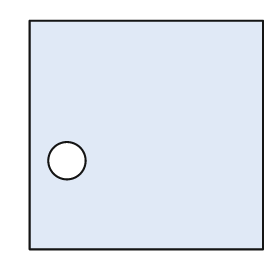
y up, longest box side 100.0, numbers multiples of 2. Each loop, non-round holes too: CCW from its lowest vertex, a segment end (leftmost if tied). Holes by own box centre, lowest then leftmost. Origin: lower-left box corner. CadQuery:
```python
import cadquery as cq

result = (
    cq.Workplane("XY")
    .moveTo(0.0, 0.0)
    .lineTo(100.0, 0.0)
    .lineTo(100.0, 98.0)
    .lineTo(0.0, 98.0)
    .close()
    .moveTo(16.0, 38.0)
    .circle(8.0)
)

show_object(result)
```